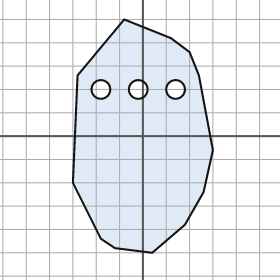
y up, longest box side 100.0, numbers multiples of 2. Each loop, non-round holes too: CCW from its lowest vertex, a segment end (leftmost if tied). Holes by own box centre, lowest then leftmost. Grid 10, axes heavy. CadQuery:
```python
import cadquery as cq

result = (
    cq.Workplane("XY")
    .moveTo(4.0, -50.0)
    .lineTo(18.0, -38.0)
    .lineTo(26.0, -24.0)
    .lineTo(30.0, -6.0)
    .lineTo(24.0, 26.0)
    .lineTo(20.0, 36.0)
    .lineTo(12.0, 42.0)
    .lineTo(-8.0, 50.0)
    .lineTo(-28.0, 26.0)
    .lineTo(-30.0, -20.0)
    .lineTo(-18.0, -44.0)
    .lineTo(-12.0, -48.0)
    .close()
    .moveTo(-18.0, 20.0)
    .circle(4.0)
    .moveTo(-2.0, 20.0)
    .circle(4.0)
    .moveTo(14.0, 20.0)
    .circle(4.0)
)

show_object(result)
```